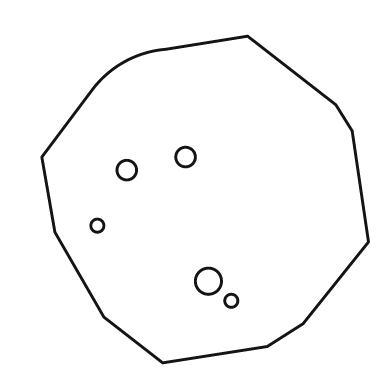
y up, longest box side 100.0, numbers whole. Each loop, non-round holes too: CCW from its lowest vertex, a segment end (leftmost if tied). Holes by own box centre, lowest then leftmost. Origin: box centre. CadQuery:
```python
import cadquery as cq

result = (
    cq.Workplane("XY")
    .moveTo(-13.0, -50.0)
    .lineTo(19.0, -45.0)
    .lineTo(30.0, -38.0)
    .lineTo(50.0, -13.0)
    .lineTo(45.0, 21.0)
    .lineTo(40.0, 29.0)
    .lineTo(13.0, 50.0)
    .lineTo(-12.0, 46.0)
    .threePointArc((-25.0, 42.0), (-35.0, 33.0))
    .lineTo(-50.0, 13.0)
    .lineTo(-46.0, -10.0)
    .lineTo(-31.0, -36.0)
    .close()
    .moveTo(8.0, -31.0)
    .circle(2.0)
    .moveTo(1.0, -25.0)
    .circle(4.0)
    .moveTo(-33.0, -8.0)
    .circle(2.0)
    .moveTo(-24.0, 9.0)
    .circle(3.0)
    .moveTo(-6.0, 13.0)
    .circle(3.0)
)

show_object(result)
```